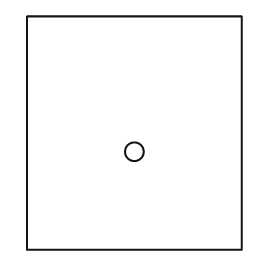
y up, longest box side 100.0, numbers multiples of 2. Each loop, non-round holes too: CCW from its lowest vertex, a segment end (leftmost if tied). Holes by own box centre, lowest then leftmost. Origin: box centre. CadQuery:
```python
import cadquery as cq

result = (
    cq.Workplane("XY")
    .moveTo(-46.0, -50.0)
    .lineTo(46.0, -50.0)
    .lineTo(46.0, 50.0)
    .lineTo(-46.0, 50.0)
    .close()
    .moveTo(0.0, -8.0)
    .circle(4.0)
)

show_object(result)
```